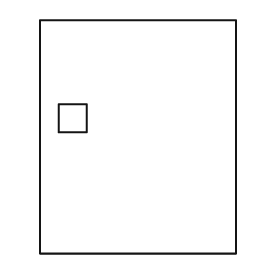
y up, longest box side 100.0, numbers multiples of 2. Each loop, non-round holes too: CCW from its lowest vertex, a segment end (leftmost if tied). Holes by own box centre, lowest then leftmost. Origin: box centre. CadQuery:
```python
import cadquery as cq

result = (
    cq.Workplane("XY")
    .moveTo(-42.0, -50.0)
    .lineTo(42.0, -50.0)
    .lineTo(42.0, 50.0)
    .lineTo(-42.0, 50.0)
    .close()
    .moveTo(-34.0, 2.0)
    .lineTo(-22.0, 2.0)
    .lineTo(-22.0, 14.0)
    .lineTo(-34.0, 14.0)
    .close()
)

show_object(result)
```